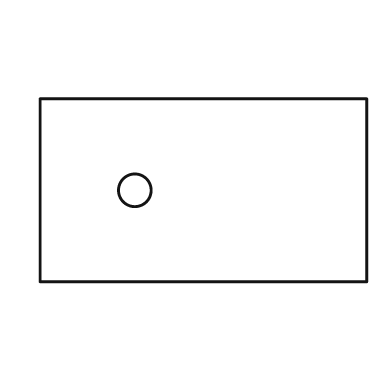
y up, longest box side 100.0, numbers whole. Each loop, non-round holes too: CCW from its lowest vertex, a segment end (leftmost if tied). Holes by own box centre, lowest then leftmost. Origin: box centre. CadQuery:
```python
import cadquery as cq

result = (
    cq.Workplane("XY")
    .moveTo(-50.0, -28.0)
    .lineTo(50.0, -28.0)
    .lineTo(50.0, 28.0)
    .lineTo(-50.0, 28.0)
    .close()
    .moveTo(-21.0, 0.0)
    .circle(5.0)
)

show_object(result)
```